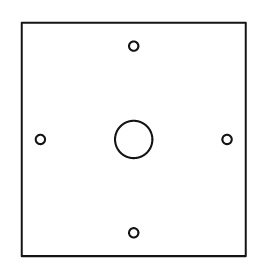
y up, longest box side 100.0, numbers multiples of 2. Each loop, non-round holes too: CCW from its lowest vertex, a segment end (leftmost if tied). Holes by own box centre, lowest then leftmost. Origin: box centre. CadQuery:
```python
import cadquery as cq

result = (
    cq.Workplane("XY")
    .moveTo(-48.0, -50.0)
    .lineTo(48.0, -50.0)
    .lineTo(48.0, 50.0)
    .lineTo(-48.0, 50.0)
    .close()
    .moveTo(0.0, -40.0)
    .circle(2.0)
    .moveTo(-40.0, 0.0)
    .circle(2.0)
    .moveTo(0.0, 0.0)
    .circle(8.0)
    .moveTo(40.0, 0.0)
    .circle(2.0)
    .moveTo(0.0, 40.0)
    .circle(2.0)
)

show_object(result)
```